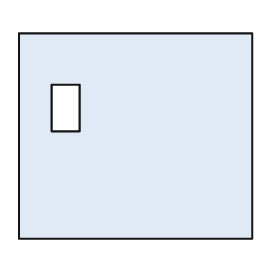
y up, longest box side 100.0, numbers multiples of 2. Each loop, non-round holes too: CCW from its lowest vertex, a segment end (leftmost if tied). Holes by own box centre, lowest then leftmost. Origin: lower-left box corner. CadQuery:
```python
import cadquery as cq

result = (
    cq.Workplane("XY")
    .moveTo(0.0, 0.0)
    .lineTo(100.0, 0.0)
    .lineTo(100.0, 88.0)
    .lineTo(0.0, 88.0)
    .close()
    .moveTo(14.0, 46.0)
    .lineTo(26.0, 46.0)
    .lineTo(26.0, 66.0)
    .lineTo(14.0, 66.0)
    .close()
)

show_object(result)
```